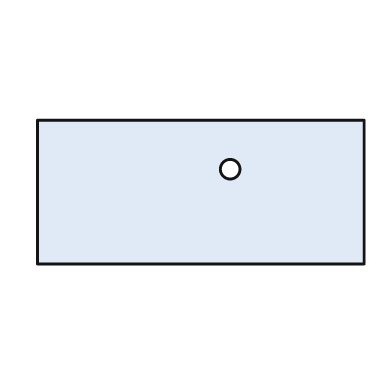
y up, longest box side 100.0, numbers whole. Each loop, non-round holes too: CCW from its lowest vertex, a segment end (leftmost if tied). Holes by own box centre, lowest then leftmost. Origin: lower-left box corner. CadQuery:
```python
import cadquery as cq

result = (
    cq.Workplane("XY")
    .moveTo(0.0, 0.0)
    .lineTo(100.0, 0.0)
    .lineTo(100.0, 44.0)
    .lineTo(0.0, 44.0)
    .close()
    .moveTo(59.0, 29.0)
    .circle(3.0)
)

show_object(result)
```